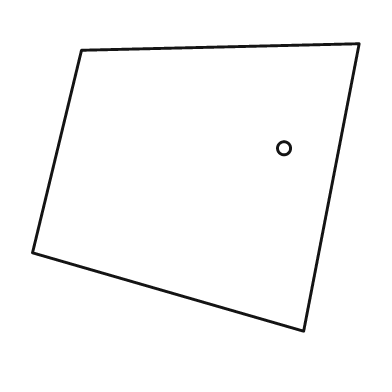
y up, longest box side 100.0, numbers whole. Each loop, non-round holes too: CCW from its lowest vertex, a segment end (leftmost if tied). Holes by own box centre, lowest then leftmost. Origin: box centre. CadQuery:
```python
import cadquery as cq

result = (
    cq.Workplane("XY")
    .moveTo(33.0, -44.0)
    .lineTo(50.0, 44.0)
    .lineTo(-35.0, 42.0)
    .lineTo(-50.0, -20.0)
    .close()
    .moveTo(27.0, 12.0)
    .circle(2.0)
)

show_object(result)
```